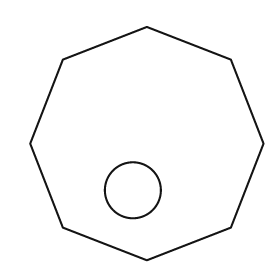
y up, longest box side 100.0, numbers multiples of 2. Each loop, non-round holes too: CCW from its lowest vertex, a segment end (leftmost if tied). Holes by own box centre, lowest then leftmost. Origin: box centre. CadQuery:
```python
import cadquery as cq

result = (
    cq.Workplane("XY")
    .moveTo(0.0, -50.0)
    .lineTo(36.0, -36.0)
    .lineTo(50.0, 0.0)
    .lineTo(36.0, 36.0)
    .lineTo(0.0, 50.0)
    .lineTo(-36.0, 36.0)
    .lineTo(-50.0, 0.0)
    .lineTo(-36.0, -36.0)
    .close()
    .moveTo(-6.0, -20.0)
    .circle(12.0)
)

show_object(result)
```